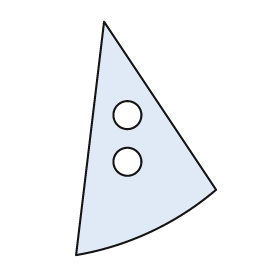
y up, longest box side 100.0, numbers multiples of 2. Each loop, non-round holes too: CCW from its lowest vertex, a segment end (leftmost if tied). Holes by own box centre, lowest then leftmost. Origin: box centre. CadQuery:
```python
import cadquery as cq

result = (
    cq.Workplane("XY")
    .moveTo(-30.0, -50.0)
    .threePointArc((2.0, -40.0), (30.0, -22.0))
    .lineTo(-18.0, 50.0)
    .close()
    .moveTo(-8.0, -10.0)
    .circle(6.0)
    .moveTo(-8.0, 10.0)
    .circle(6.0)
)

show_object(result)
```